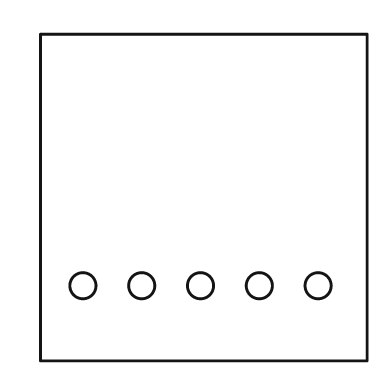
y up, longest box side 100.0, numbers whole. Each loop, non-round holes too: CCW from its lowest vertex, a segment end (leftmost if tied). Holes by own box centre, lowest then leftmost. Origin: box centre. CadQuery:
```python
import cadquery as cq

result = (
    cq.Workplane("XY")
    .moveTo(-50.0, -50.0)
    .lineTo(50.0, -50.0)
    .lineTo(50.0, 50.0)
    .lineTo(-50.0, 50.0)
    .close()
    .moveTo(-37.0, -27.0)
    .circle(4.0)
    .moveTo(-19.0, -27.0)
    .circle(4.0)
    .moveTo(-1.0, -27.0)
    .circle(4.0)
    .moveTo(17.0, -27.0)
    .circle(4.0)
    .moveTo(35.0, -27.0)
    .circle(4.0)
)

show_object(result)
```